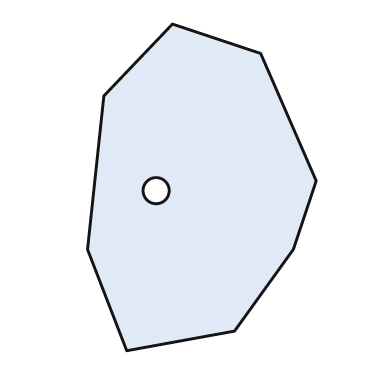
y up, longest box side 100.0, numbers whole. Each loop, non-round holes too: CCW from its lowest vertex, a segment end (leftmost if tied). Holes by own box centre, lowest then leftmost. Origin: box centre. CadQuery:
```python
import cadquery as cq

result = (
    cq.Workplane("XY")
    .moveTo(-23.0, -50.0)
    .lineTo(10.0, -44.0)
    .lineTo(28.0, -19.0)
    .lineTo(35.0, 2.0)
    .lineTo(18.0, 41.0)
    .lineTo(-9.0, 50.0)
    .lineTo(-30.0, 28.0)
    .lineTo(-35.0, -19.0)
    .close()
    .moveTo(-14.0, -1.0)
    .circle(4.0)
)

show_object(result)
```